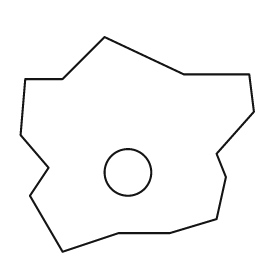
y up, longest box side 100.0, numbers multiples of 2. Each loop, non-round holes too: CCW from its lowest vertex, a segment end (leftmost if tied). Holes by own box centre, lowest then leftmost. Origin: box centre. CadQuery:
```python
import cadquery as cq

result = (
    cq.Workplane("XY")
    .moveTo(-32.0, -46.0)
    .lineTo(-8.0, -38.0)
    .lineTo(14.0, -38.0)
    .lineTo(34.0, -32.0)
    .lineTo(38.0, -14.0)
    .lineTo(34.0, -4.0)
    .lineTo(50.0, 14.0)
    .lineTo(48.0, 30.0)
    .lineTo(20.0, 30.0)
    .lineTo(-14.0, 46.0)
    .lineTo(-32.0, 28.0)
    .lineTo(-48.0, 28.0)
    .lineTo(-50.0, 4.0)
    .lineTo(-38.0, -10.0)
    .lineTo(-46.0, -22.0)
    .close()
    .moveTo(-4.0, -12.0)
    .circle(10.0)
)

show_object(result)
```